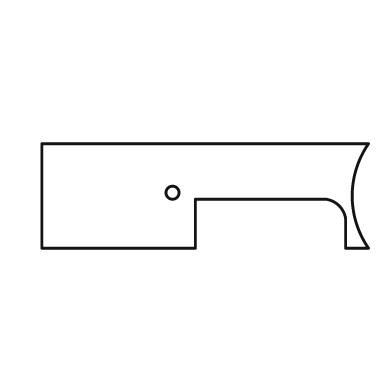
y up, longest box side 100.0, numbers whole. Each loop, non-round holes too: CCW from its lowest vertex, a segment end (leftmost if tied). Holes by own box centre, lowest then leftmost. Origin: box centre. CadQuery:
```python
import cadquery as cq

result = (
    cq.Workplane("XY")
    .moveTo(-50.0, -16.0)
    .lineTo(-3.0, -16.0)
    .lineTo(-3.0, -1.0)
    .lineTo(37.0, -1.0)
    .threePointArc((41.0, -3.0), (43.0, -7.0))
    .lineTo(43.0, -16.0)
    .lineTo(50.0, -16.0)
    .threePointArc((45.0, 0.0), (50.0, 16.0))
    .lineTo(-50.0, 16.0)
    .close()
    .moveTo(-10.0, 1.0)
    .circle(2.0)
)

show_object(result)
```